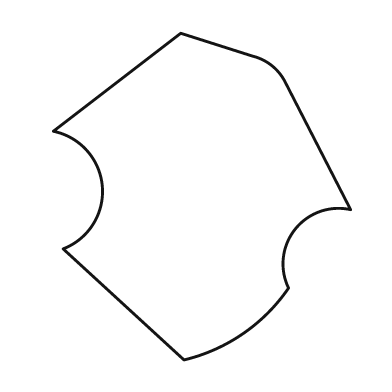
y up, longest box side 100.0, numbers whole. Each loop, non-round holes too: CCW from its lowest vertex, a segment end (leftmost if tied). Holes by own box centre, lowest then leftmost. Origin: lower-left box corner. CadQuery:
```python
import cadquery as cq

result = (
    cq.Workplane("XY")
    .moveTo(40.0, 0.0)
    .threePointArc((58.0, 8.0), (72.0, 22.0))
    .threePointArc((74.0, 40.0), (91.0, 46.0))
    .lineTo(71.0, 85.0)
    .threePointArc((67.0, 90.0), (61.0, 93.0))
    .lineTo(39.0, 100.0)
    .lineTo(0.0, 70.0)
    .threePointArc((15.0, 53.0), (3.0, 34.0))
    .close()
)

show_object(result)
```